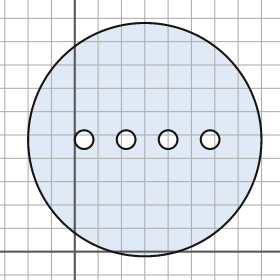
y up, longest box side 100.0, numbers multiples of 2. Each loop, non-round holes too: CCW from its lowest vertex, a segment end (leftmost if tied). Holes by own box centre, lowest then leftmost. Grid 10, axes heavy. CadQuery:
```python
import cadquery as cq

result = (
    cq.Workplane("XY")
    .moveTo(30.0, 48.0)
    .circle(50.0)
    .moveTo(4.0, 48.0)
    .circle(4.0)
    .moveTo(22.0, 48.0)
    .circle(4.0)
    .moveTo(40.0, 48.0)
    .circle(4.0)
    .moveTo(58.0, 48.0)
    .circle(4.0)
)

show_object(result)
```